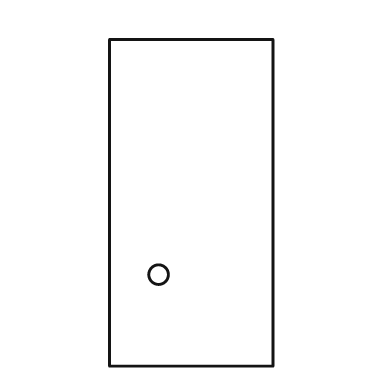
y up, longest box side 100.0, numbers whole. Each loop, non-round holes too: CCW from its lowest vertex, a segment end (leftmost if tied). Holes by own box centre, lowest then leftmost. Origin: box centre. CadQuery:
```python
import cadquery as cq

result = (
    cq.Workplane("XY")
    .moveTo(-25.0, -50.0)
    .lineTo(25.0, -50.0)
    .lineTo(25.0, 50.0)
    .lineTo(-25.0, 50.0)
    .close()
    .moveTo(-10.0, -22.0)
    .circle(3.0)
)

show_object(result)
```